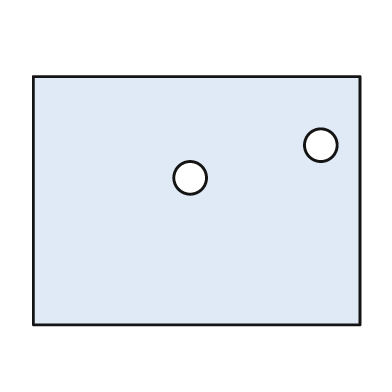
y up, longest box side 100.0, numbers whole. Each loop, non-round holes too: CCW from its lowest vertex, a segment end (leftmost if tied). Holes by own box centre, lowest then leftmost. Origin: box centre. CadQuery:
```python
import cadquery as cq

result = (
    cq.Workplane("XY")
    .moveTo(-50.0, -38.0)
    .lineTo(50.0, -38.0)
    .lineTo(50.0, 38.0)
    .lineTo(-50.0, 38.0)
    .close()
    .moveTo(-2.0, 7.0)
    .circle(5.0)
    .moveTo(38.0, 17.0)
    .circle(5.0)
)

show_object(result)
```